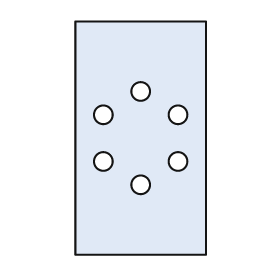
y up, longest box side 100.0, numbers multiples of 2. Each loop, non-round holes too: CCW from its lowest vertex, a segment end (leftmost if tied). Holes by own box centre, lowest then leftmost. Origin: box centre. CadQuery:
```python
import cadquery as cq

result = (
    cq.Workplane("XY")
    .moveTo(-28.0, -50.0)
    .lineTo(28.0, -50.0)
    .lineTo(28.0, 50.0)
    .lineTo(-28.0, 50.0)
    .close()
    .moveTo(0.0, -20.0)
    .circle(4.0)
    .moveTo(-16.0, -10.0)
    .circle(4.0)
    .moveTo(16.0, -10.0)
    .circle(4.0)
    .moveTo(-16.0, 10.0)
    .circle(4.0)
    .moveTo(16.0, 10.0)
    .circle(4.0)
    .moveTo(0.0, 20.0)
    .circle(4.0)
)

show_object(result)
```